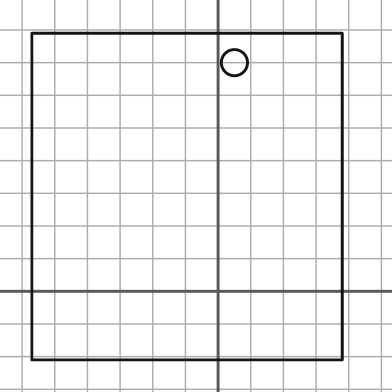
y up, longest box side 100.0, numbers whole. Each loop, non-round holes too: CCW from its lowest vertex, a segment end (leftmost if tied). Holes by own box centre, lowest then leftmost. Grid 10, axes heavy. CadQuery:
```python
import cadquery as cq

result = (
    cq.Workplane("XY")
    .moveTo(-57.0, -21.0)
    .lineTo(38.0, -21.0)
    .lineTo(38.0, 79.0)
    .lineTo(-57.0, 79.0)
    .close()
    .moveTo(5.0, 70.0)
    .circle(4.0)
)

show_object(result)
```